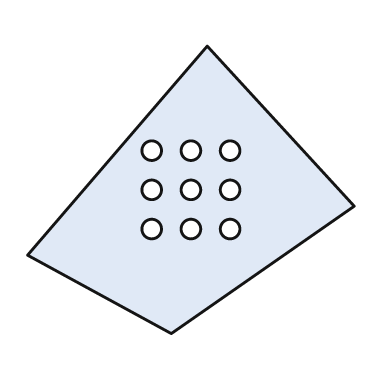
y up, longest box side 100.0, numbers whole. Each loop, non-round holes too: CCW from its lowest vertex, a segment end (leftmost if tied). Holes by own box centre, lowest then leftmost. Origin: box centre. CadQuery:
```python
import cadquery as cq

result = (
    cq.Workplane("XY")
    .moveTo(-6.0, -44.0)
    .lineTo(50.0, -5.0)
    .lineTo(5.0, 44.0)
    .lineTo(-50.0, -20.0)
    .close()
    .moveTo(-12.0, -12.0)
    .circle(3.0)
    .moveTo(0.0, -12.0)
    .circle(3.0)
    .moveTo(12.0, -12.0)
    .circle(3.0)
    .moveTo(-12.0, 0.0)
    .circle(3.0)
    .moveTo(0.0, 0.0)
    .circle(3.0)
    .moveTo(12.0, 0.0)
    .circle(3.0)
    .moveTo(-12.0, 12.0)
    .circle(3.0)
    .moveTo(0.0, 12.0)
    .circle(3.0)
    .moveTo(12.0, 12.0)
    .circle(3.0)
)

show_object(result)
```